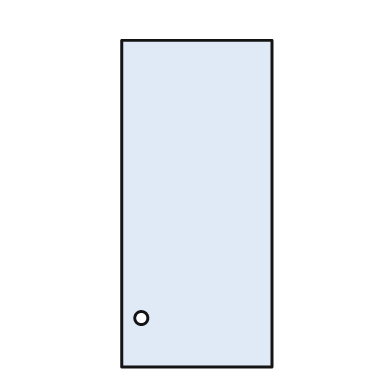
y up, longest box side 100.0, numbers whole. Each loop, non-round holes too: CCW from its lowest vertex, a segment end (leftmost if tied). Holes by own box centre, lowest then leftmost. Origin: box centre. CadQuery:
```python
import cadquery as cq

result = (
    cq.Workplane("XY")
    .moveTo(-23.0, -50.0)
    .lineTo(23.0, -50.0)
    .lineTo(23.0, 50.0)
    .lineTo(-23.0, 50.0)
    .close()
    .moveTo(-17.0, -35.0)
    .circle(2.0)
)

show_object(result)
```